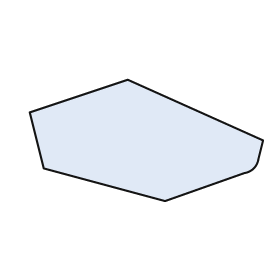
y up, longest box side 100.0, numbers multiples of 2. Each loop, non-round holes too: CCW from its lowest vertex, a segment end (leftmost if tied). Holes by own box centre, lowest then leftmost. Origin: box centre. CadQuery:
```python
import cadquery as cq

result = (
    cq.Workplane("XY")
    .moveTo(8.0, -26.0)
    .lineTo(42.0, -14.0)
    .threePointArc((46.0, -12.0), (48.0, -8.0))
    .lineTo(50.0, 0.0)
    .lineTo(-8.0, 26.0)
    .lineTo(-50.0, 12.0)
    .lineTo(-44.0, -12.0)
    .close()
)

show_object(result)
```